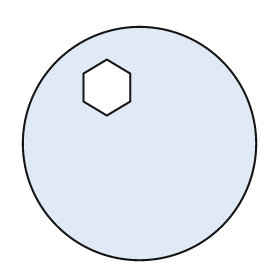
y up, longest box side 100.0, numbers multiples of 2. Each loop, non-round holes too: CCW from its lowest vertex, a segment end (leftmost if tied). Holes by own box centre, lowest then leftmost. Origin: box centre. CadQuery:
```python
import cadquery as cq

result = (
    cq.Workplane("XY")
    .moveTo(0.0, 0.0)
    .circle(50.0)
    .moveTo(-14.0, 12.0)
    .lineTo(-4.0, 18.0)
    .lineTo(-4.0, 30.0)
    .lineTo(-14.0, 36.0)
    .lineTo(-24.0, 30.0)
    .lineTo(-24.0, 18.0)
    .close()
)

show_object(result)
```